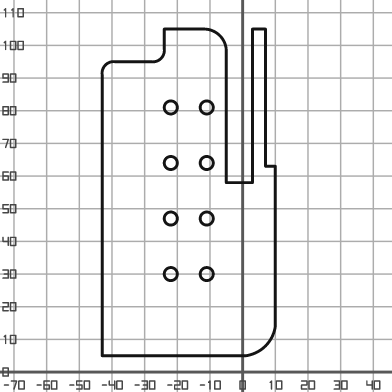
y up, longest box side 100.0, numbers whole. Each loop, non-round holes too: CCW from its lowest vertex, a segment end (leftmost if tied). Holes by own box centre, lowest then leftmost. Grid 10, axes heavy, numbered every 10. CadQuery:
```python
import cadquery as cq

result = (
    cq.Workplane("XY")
    .moveTo(-43.0, 5.0)
    .lineTo(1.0, 5.0)
    .threePointArc((7.0, 8.0), (10.0, 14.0))
    .lineTo(10.0, 63.0)
    .lineTo(7.0, 63.0)
    .lineTo(7.0, 105.0)
    .lineTo(3.0, 105.0)
    .lineTo(3.0, 58.0)
    .lineTo(-5.0, 58.0)
    .lineTo(-5.0, 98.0)
    .threePointArc((-7.0, 103.0), (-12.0, 105.0))
    .lineTo(-24.0, 105.0)
    .lineTo(-24.0, 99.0)
    .threePointArc((-25.0, 96.0), (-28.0, 95.0))
    .lineTo(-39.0, 95.0)
    .threePointArc((-42.0, 94.0), (-43.0, 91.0))
    .close()
    .moveTo(-22.0, 30.0)
    .circle(2.0)
    .moveTo(-11.0, 30.0)
    .circle(2.0)
    .moveTo(-22.0, 47.0)
    .circle(2.0)
    .moveTo(-11.0, 47.0)
    .circle(2.0)
    .moveTo(-22.0, 64.0)
    .circle(2.0)
    .moveTo(-11.0, 64.0)
    .circle(2.0)
    .moveTo(-22.0, 81.0)
    .circle(2.0)
    .moveTo(-11.0, 81.0)
    .circle(2.0)
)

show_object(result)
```